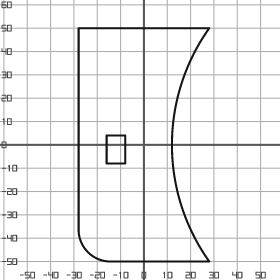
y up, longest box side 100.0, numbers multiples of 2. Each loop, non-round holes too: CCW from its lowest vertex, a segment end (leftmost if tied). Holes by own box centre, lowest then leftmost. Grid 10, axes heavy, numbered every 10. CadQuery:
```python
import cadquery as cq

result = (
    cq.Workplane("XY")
    .moveTo(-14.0, -50.0)
    .lineTo(28.0, -50.0)
    .threePointArc((12.0, 0.0), (28.0, 50.0))
    .lineTo(-28.0, 50.0)
    .lineTo(-28.0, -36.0)
    .threePointArc((-24.0, -46.0), (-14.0, -50.0))
    .close()
    .moveTo(-16.0, -8.0)
    .lineTo(-8.0, -8.0)
    .lineTo(-8.0, 4.0)
    .lineTo(-16.0, 4.0)
    .close()
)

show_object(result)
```